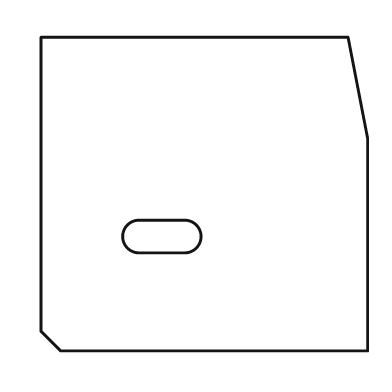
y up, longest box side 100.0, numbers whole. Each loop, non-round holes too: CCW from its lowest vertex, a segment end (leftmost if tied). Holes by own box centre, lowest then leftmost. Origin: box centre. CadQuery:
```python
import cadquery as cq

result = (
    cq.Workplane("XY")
    .moveTo(-44.0, -48.0)
    .lineTo(50.0, -48.0)
    .lineTo(50.0, 17.0)
    .lineTo(44.0, 48.0)
    .lineTo(-50.0, 48.0)
    .lineTo(-50.0, -42.0)
    .close()
    .moveTo(-20.0, -18.0)
    .lineTo(-6.0, -18.0)
    .threePointArc((-1.0, -13.0), (-6.0, -8.0))
    .lineTo(-20.0, -8.0)
    .threePointArc((-25.0, -13.0), (-20.0, -18.0))
    .close()
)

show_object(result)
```